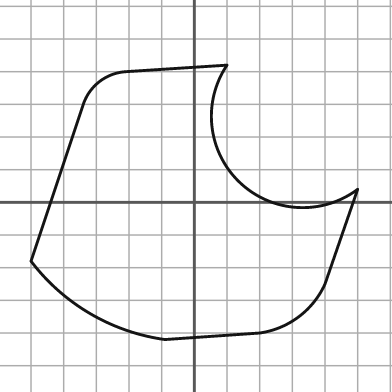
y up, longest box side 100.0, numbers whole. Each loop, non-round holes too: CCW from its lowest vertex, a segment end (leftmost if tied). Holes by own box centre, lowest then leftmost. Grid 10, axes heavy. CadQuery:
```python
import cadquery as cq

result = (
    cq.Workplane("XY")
    .moveTo(-9.0, -42.0)
    .lineTo(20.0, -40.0)
    .threePointArc((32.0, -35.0), (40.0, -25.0))
    .lineTo(50.0, 4.0)
    .threePointArc((14.0, 6.0), (10.0, 42.0))
    .lineTo(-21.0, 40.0)
    .threePointArc((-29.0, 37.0), (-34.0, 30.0))
    .lineTo(-50.0, -18.0)
    .threePointArc((-32.0, -34.0), (-9.0, -42.0))
    .close()
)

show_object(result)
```